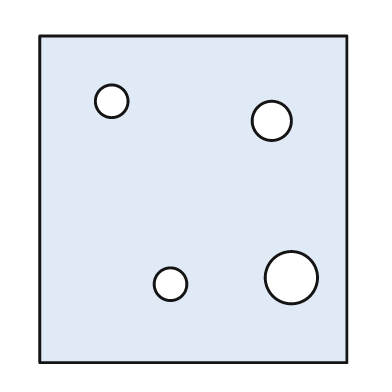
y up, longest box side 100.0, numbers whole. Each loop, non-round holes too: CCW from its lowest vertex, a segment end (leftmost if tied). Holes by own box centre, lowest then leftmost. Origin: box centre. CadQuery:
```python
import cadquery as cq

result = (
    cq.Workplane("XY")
    .moveTo(-47.0, -50.0)
    .lineTo(47.0, -50.0)
    .lineTo(47.0, 50.0)
    .lineTo(-47.0, 50.0)
    .close()
    .moveTo(-7.0, -26.0)
    .circle(5.0)
    .moveTo(30.0, -24.0)
    .circle(8.0)
    .moveTo(24.0, 24.0)
    .circle(6.0)
    .moveTo(-25.0, 30.0)
    .circle(5.0)
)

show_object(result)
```